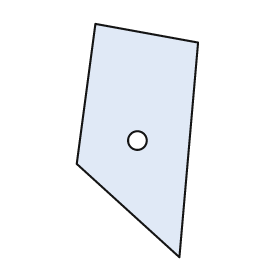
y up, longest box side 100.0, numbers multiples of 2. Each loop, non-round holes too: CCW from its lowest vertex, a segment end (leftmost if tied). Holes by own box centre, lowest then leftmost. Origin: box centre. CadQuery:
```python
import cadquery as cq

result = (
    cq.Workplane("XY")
    .moveTo(18.0, -50.0)
    .lineTo(26.0, 42.0)
    .lineTo(-18.0, 50.0)
    .lineTo(-26.0, -10.0)
    .close()
    .moveTo(0.0, 0.0)
    .circle(4.0)
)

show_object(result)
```